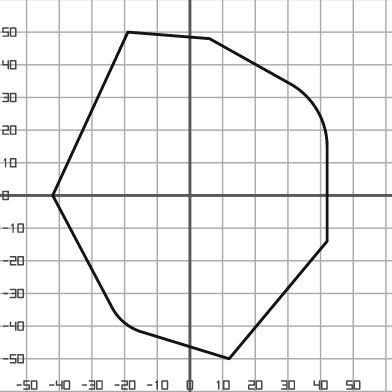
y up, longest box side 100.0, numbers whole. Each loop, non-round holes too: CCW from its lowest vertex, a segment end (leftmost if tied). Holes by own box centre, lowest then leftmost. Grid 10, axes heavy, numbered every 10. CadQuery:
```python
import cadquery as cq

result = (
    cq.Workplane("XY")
    .moveTo(12.0, -50.0)
    .lineTo(42.0, -14.0)
    .lineTo(42.0, 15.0)
    .threePointArc((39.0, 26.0), (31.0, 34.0))
    .lineTo(6.0, 48.0)
    .lineTo(-19.0, 50.0)
    .lineTo(-42.0, 0.0)
    .lineTo(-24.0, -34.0)
    .threePointArc((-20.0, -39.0), (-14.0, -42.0))
    .close()
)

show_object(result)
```